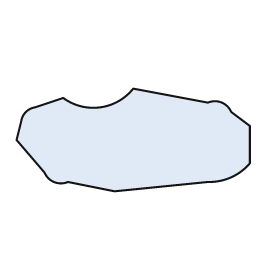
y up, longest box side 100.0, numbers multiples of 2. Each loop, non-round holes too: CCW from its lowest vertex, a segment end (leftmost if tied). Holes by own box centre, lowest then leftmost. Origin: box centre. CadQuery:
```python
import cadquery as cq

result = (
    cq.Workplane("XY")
    .moveTo(-8.0, -22.0)
    .lineTo(32.0, -18.0)
    .threePointArc((42.0, -16.0), (50.0, -10.0))
    .lineTo(50.0, 6.0)
    .lineTo(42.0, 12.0)
    .threePointArc((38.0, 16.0), (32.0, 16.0))
    .lineTo(0.0, 22.0)
    .threePointArc((-14.0, 14.0), (-30.0, 18.0))
    .lineTo(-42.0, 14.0)
    .threePointArc((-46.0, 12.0), (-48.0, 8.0))
    .lineTo(-50.0, 0.0)
    .lineTo(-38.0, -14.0)
    .threePointArc((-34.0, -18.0), (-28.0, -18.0))
    .close()
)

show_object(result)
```